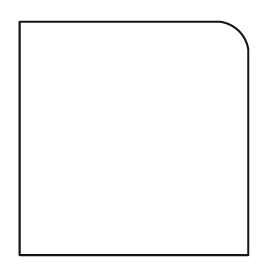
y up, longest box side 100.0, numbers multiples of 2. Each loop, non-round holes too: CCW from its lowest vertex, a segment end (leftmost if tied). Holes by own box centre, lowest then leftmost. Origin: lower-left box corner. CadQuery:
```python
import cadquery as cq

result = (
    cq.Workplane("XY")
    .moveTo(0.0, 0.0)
    .lineTo(98.0, 0.0)
    .lineTo(98.0, 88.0)
    .threePointArc((94.0, 96.0), (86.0, 100.0))
    .lineTo(0.0, 100.0)
    .close()
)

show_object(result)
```